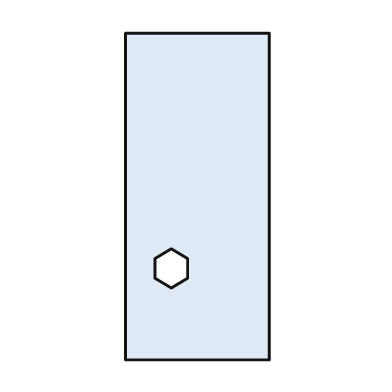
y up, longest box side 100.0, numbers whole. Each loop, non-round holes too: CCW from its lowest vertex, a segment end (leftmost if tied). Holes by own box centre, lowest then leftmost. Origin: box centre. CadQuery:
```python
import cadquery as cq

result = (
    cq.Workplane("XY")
    .moveTo(-22.0, -50.0)
    .lineTo(22.0, -50.0)
    .lineTo(22.0, 50.0)
    .lineTo(-22.0, 50.0)
    .close()
    .moveTo(-8.0, -28.0)
    .lineTo(-3.0, -25.0)
    .lineTo(-3.0, -19.0)
    .lineTo(-8.0, -16.0)
    .lineTo(-13.0, -19.0)
    .lineTo(-13.0, -25.0)
    .close()
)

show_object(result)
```